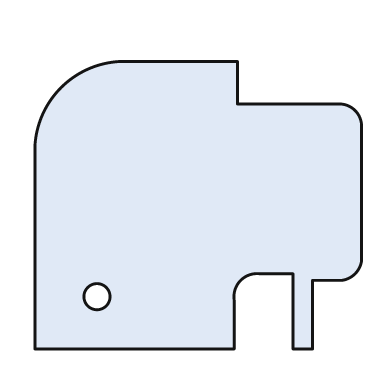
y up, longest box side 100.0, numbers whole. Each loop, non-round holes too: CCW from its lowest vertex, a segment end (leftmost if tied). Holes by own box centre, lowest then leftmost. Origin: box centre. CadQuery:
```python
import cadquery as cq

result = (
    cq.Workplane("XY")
    .moveTo(-50.0, -44.0)
    .lineTo(11.0, -44.0)
    .lineTo(11.0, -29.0)
    .threePointArc((13.0, -23.0), (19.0, -21.0))
    .lineTo(29.0, -21.0)
    .lineTo(29.0, -44.0)
    .lineTo(35.0, -44.0)
    .lineTo(35.0, -23.0)
    .lineTo(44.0, -23.0)
    .threePointArc((48.0, -21.0), (50.0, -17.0))
    .lineTo(50.0, 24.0)
    .threePointArc((48.0, 29.0), (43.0, 31.0))
    .lineTo(12.0, 31.0)
    .lineTo(12.0, 44.0)
    .lineTo(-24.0, 44.0)
    .threePointArc((-42.0, 36.0), (-50.0, 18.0))
    .close()
    .moveTo(-31.0, -28.0)
    .circle(4.0)
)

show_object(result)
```